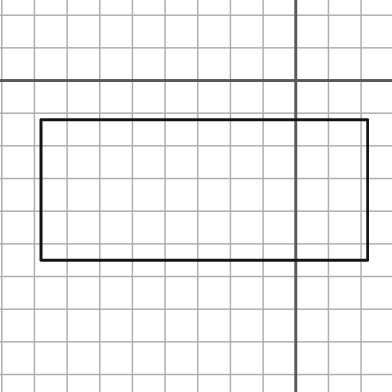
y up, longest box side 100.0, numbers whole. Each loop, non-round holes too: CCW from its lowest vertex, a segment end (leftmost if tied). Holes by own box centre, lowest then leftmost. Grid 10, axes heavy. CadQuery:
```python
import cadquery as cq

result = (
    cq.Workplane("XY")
    .moveTo(-78.0, -55.0)
    .lineTo(22.0, -55.0)
    .lineTo(22.0, -12.0)
    .lineTo(-78.0, -12.0)
    .close()
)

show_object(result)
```